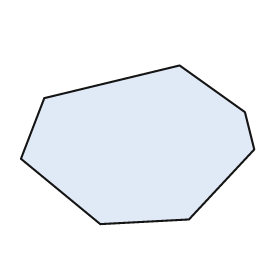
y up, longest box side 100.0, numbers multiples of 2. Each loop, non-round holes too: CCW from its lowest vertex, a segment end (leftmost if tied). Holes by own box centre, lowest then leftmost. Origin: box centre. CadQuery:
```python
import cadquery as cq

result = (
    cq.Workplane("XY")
    .moveTo(-16.0, -34.0)
    .lineTo(22.0, -32.0)
    .lineTo(50.0, -2.0)
    .lineTo(46.0, 14.0)
    .lineTo(18.0, 34.0)
    .lineTo(-40.0, 20.0)
    .lineTo(-50.0, -6.0)
    .close()
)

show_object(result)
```